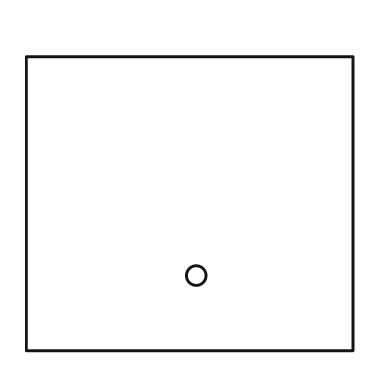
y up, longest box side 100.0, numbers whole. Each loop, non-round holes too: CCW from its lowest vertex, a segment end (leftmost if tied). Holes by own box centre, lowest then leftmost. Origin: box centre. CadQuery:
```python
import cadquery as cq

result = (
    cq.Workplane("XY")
    .moveTo(-50.0, -45.0)
    .lineTo(50.0, -45.0)
    .lineTo(50.0, 45.0)
    .lineTo(-50.0, 45.0)
    .close()
    .moveTo(2.0, -22.0)
    .circle(3.0)
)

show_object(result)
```